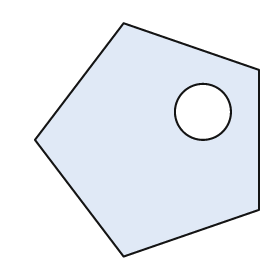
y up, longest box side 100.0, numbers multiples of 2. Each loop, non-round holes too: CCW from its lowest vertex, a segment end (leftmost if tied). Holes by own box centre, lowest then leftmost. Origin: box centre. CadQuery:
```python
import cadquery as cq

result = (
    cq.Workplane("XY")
    .moveTo(-10.0, -50.0)
    .lineTo(48.0, -30.0)
    .lineTo(48.0, 30.0)
    .lineTo(-10.0, 50.0)
    .lineTo(-48.0, 0.0)
    .close()
    .moveTo(24.0, 12.0)
    .circle(12.0)
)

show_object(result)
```